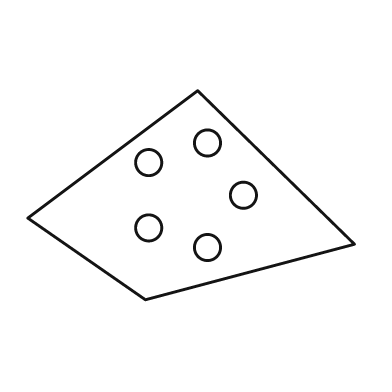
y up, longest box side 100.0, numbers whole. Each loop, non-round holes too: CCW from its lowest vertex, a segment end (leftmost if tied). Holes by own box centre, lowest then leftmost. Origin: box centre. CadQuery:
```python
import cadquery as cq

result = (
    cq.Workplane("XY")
    .moveTo(-14.0, -32.0)
    .lineTo(50.0, -15.0)
    .lineTo(2.0, 32.0)
    .lineTo(-50.0, -7.0)
    .close()
    .moveTo(5.0, -16.0)
    .circle(4.0)
    .moveTo(-13.0, -10.0)
    .circle(4.0)
    .moveTo(16.0, 0.0)
    .circle(4.0)
    .moveTo(-13.0, 10.0)
    .circle(4.0)
    .moveTo(5.0, 16.0)
    .circle(4.0)
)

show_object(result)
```